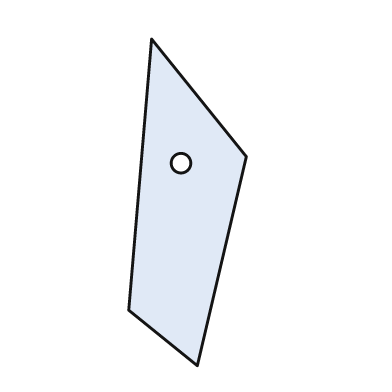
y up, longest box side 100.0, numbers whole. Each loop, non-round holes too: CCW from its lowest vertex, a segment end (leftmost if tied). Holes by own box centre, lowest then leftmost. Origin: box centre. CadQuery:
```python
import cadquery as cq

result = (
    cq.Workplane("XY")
    .moveTo(3.0, -50.0)
    .lineTo(18.0, 14.0)
    .lineTo(-11.0, 50.0)
    .lineTo(-18.0, -33.0)
    .close()
    .moveTo(-2.0, 12.0)
    .circle(3.0)
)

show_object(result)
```